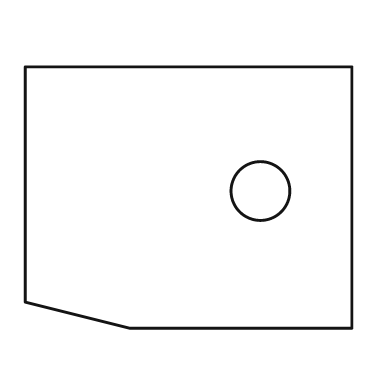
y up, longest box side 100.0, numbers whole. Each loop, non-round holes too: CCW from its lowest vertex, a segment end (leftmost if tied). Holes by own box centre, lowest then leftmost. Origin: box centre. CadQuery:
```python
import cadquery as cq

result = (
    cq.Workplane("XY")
    .moveTo(-18.0, -40.0)
    .lineTo(50.0, -40.0)
    .lineTo(50.0, 40.0)
    .lineTo(-50.0, 40.0)
    .lineTo(-50.0, -32.0)
    .close()
    .moveTo(22.0, 2.0)
    .circle(9.0)
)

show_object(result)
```